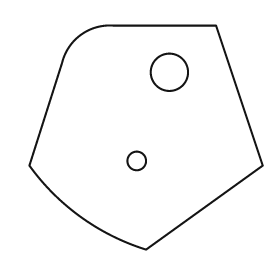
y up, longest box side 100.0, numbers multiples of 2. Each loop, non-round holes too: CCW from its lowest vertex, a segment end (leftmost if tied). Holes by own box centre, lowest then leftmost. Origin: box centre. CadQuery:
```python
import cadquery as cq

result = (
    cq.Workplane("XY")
    .moveTo(0.0, -48.0)
    .lineTo(50.0, -12.0)
    .lineTo(30.0, 48.0)
    .lineTo(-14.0, 48.0)
    .threePointArc((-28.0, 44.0), (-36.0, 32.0))
    .lineTo(-50.0, -12.0)
    .threePointArc((-28.0, -34.0), (0.0, -48.0))
    .close()
    .moveTo(-4.0, -10.0)
    .circle(4.0)
    .moveTo(10.0, 28.0)
    .circle(8.0)
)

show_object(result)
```